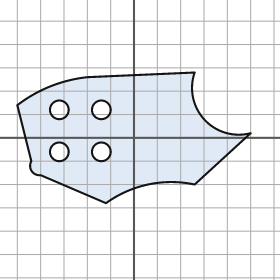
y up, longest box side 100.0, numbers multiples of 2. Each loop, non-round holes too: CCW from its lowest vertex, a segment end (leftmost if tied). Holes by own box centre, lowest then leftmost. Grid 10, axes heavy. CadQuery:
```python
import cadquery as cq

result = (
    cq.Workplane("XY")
    .moveTo(-12.0, -28.0)
    .threePointArc((6.0, -20.0), (26.0, -20.0))
    .lineTo(50.0, 2.0)
    .threePointArc((30.0, 8.0), (26.0, 28.0))
    .lineTo(-20.0, 26.0)
    .threePointArc((-36.0, 22.0), (-50.0, 14.0))
    .lineTo(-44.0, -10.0)
    .threePointArc((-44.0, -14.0), (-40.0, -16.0))
    .close()
    .moveTo(-32.0, -6.0)
    .circle(4.0)
    .moveTo(-14.0, -6.0)
    .circle(4.0)
    .moveTo(-32.0, 12.0)
    .circle(4.0)
    .moveTo(-14.0, 12.0)
    .circle(4.0)
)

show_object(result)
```